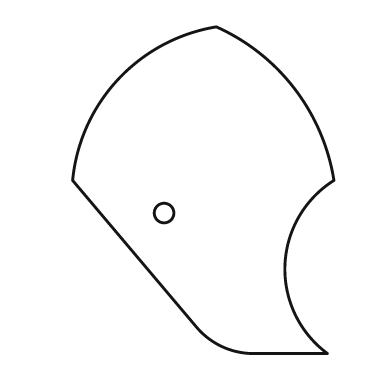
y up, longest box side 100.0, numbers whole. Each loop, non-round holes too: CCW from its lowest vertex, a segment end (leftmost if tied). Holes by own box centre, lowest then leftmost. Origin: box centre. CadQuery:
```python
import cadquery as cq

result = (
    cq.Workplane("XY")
    .moveTo(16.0, -50.0)
    .lineTo(38.0, -50.0)
    .threePointArc((25.0, -23.0), (40.0, 3.0))
    .threePointArc((28.0, 31.0), (4.0, 50.0))
    .threePointArc((-26.0, 34.0), (-40.0, 3.0))
    .lineTo(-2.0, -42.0)
    .threePointArc((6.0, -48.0), (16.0, -50.0))
    .close()
    .moveTo(-12.0, -7.0)
    .circle(3.0)
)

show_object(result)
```